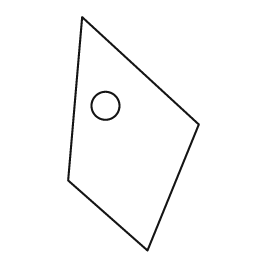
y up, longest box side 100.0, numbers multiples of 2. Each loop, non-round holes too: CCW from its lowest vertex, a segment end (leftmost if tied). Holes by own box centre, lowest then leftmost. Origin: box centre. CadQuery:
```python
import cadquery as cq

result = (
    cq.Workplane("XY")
    .moveTo(6.0, -50.0)
    .lineTo(28.0, 4.0)
    .lineTo(-22.0, 50.0)
    .lineTo(-28.0, -20.0)
    .close()
    .moveTo(-12.0, 12.0)
    .circle(6.0)
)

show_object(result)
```